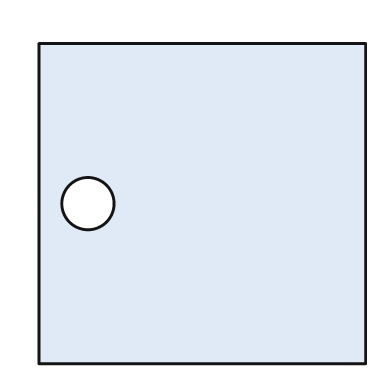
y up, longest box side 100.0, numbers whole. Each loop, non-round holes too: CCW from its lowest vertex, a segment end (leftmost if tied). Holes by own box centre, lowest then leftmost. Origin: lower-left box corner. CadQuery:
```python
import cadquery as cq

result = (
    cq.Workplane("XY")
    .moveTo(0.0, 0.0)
    .lineTo(100.0, 0.0)
    .lineTo(100.0, 98.0)
    .lineTo(0.0, 98.0)
    .close()
    .moveTo(15.0, 49.0)
    .circle(8.0)
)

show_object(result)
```